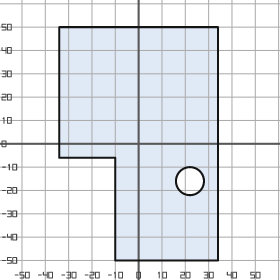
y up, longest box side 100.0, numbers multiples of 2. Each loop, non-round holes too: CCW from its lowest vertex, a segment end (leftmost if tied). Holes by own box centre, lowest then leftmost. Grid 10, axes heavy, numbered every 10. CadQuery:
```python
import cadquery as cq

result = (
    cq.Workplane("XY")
    .moveTo(-10.0, -50.0)
    .lineTo(34.0, -50.0)
    .lineTo(34.0, 50.0)
    .lineTo(-34.0, 50.0)
    .lineTo(-34.0, -6.0)
    .lineTo(-10.0, -6.0)
    .close()
    .moveTo(22.0, -16.0)
    .circle(6.0)
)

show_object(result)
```